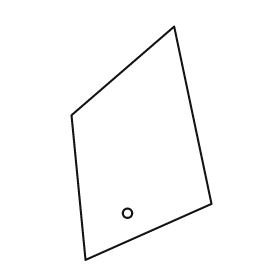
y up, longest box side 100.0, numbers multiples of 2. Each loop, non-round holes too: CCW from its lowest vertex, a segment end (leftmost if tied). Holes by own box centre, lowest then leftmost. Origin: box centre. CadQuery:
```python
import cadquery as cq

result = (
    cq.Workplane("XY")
    .moveTo(-24.0, -50.0)
    .lineTo(30.0, -26.0)
    .lineTo(14.0, 50.0)
    .lineTo(-30.0, 12.0)
    .close()
    .moveTo(-6.0, -30.0)
    .circle(2.0)
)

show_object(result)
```